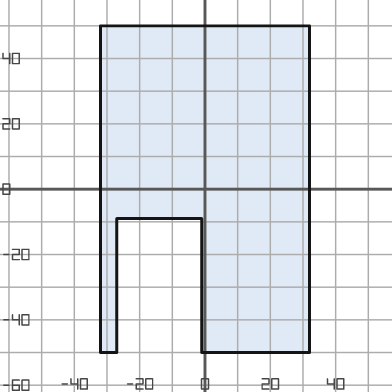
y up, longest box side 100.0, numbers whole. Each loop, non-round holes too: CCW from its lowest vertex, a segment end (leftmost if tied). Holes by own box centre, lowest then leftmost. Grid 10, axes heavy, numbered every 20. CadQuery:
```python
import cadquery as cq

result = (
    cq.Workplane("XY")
    .moveTo(-32.0, -50.0)
    .lineTo(-27.0, -50.0)
    .lineTo(-27.0, -9.0)
    .lineTo(-1.0, -9.0)
    .lineTo(-1.0, -50.0)
    .lineTo(32.0, -50.0)
    .lineTo(32.0, 50.0)
    .lineTo(-32.0, 50.0)
    .close()
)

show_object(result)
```